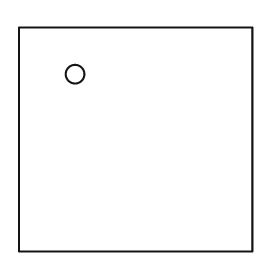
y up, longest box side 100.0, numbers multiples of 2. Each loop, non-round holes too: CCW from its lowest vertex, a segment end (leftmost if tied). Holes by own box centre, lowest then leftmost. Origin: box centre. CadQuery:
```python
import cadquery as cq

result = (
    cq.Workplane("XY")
    .moveTo(-50.0, -48.0)
    .lineTo(50.0, -48.0)
    .lineTo(50.0, 48.0)
    .lineTo(-50.0, 48.0)
    .close()
    .moveTo(-26.0, 28.0)
    .circle(4.0)
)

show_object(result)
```